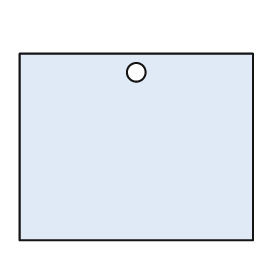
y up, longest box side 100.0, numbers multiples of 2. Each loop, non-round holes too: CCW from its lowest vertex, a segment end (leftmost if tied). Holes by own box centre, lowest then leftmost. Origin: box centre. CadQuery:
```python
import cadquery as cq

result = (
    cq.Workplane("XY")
    .moveTo(-50.0, -40.0)
    .lineTo(50.0, -40.0)
    .lineTo(50.0, 40.0)
    .lineTo(-50.0, 40.0)
    .close()
    .moveTo(0.0, 32.0)
    .circle(4.0)
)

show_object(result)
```